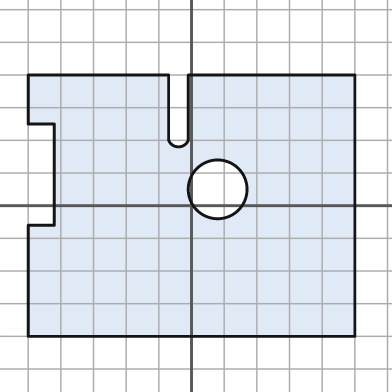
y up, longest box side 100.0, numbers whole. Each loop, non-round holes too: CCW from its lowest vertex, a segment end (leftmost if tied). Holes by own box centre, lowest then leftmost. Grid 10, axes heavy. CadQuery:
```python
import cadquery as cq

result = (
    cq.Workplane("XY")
    .moveTo(-50.0, -40.0)
    .lineTo(50.0, -40.0)
    .lineTo(50.0, 40.0)
    .lineTo(-1.0, 40.0)
    .lineTo(-1.0, 20.0)
    .threePointArc((-4.0, 18.0), (-7.0, 20.0))
    .lineTo(-7.0, 40.0)
    .lineTo(-50.0, 40.0)
    .lineTo(-50.0, 25.0)
    .lineTo(-42.0, 25.0)
    .lineTo(-42.0, -6.0)
    .lineTo(-50.0, -6.0)
    .close()
    .moveTo(8.0, 5.0)
    .circle(9.0)
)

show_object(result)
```